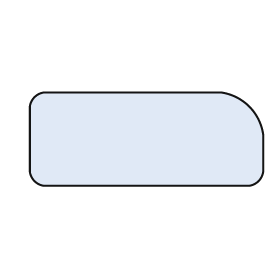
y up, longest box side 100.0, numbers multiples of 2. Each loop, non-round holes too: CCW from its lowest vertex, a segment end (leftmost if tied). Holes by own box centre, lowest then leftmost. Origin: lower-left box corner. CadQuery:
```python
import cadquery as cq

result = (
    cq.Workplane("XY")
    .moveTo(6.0, 0.0)
    .lineTo(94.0, 0.0)
    .threePointArc((98.0, 2.0), (100.0, 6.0))
    .lineTo(100.0, 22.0)
    .threePointArc((94.0, 34.0), (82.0, 40.0))
    .lineTo(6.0, 40.0)
    .threePointArc((2.0, 38.0), (0.0, 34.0))
    .lineTo(0.0, 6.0)
    .threePointArc((2.0, 2.0), (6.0, 0.0))
    .close()
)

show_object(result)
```